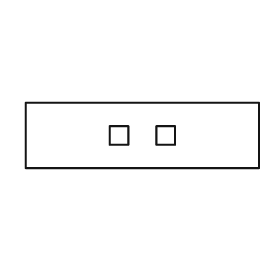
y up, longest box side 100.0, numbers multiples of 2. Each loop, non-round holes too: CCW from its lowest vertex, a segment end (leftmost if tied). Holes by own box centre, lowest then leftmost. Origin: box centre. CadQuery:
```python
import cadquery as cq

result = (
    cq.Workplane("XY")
    .moveTo(-50.0, -14.0)
    .lineTo(50.0, -14.0)
    .lineTo(50.0, 14.0)
    .lineTo(-50.0, 14.0)
    .close()
    .moveTo(-14.0, -4.0)
    .lineTo(-6.0, -4.0)
    .lineTo(-6.0, 4.0)
    .lineTo(-14.0, 4.0)
    .close()
    .moveTo(6.0, -4.0)
    .lineTo(14.0, -4.0)
    .lineTo(14.0, 4.0)
    .lineTo(6.0, 4.0)
    .close()
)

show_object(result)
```